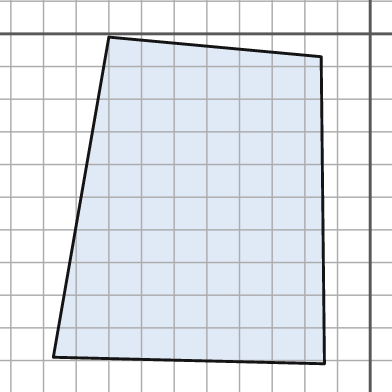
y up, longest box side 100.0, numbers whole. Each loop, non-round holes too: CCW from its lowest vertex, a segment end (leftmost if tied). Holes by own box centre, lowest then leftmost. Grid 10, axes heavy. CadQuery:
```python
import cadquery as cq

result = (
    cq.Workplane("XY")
    .moveTo(-14.0, -101.0)
    .lineTo(-15.0, -7.0)
    .lineTo(-80.0, -1.0)
    .lineTo(-97.0, -99.0)
    .close()
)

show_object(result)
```